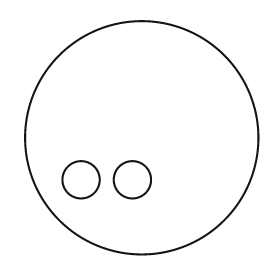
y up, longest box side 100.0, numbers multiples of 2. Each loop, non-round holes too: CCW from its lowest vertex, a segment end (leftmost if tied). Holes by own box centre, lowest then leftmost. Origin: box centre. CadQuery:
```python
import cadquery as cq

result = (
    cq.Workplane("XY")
    .moveTo(0.0, 0.0)
    .circle(50.0)
    .moveTo(-26.0, -18.0)
    .circle(8.0)
    .moveTo(-4.0, -18.0)
    .circle(8.0)
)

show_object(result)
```